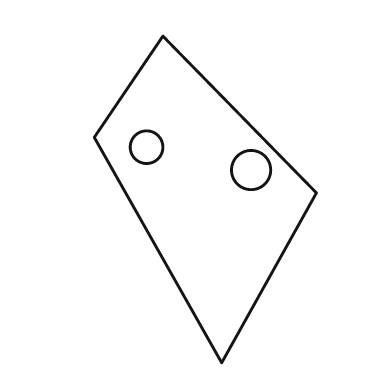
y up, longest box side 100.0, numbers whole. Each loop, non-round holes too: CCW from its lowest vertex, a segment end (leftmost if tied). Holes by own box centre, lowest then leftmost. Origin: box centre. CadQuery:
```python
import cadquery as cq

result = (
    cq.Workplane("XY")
    .moveTo(5.0, -50.0)
    .lineTo(34.0, 2.0)
    .lineTo(-13.0, 50.0)
    .lineTo(-34.0, 19.0)
    .close()
    .moveTo(14.0, 9.0)
    .circle(6.0)
    .moveTo(-18.0, 16.0)
    .circle(5.0)
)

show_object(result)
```